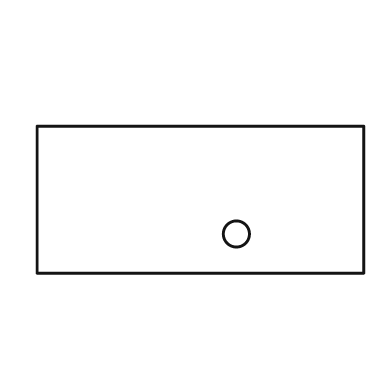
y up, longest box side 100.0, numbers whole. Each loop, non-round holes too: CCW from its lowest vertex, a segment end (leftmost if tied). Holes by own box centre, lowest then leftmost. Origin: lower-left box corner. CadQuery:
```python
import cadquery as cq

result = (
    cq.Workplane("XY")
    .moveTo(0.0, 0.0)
    .lineTo(100.0, 0.0)
    .lineTo(100.0, 45.0)
    .lineTo(0.0, 45.0)
    .close()
    .moveTo(61.0, 12.0)
    .circle(4.0)
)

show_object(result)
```